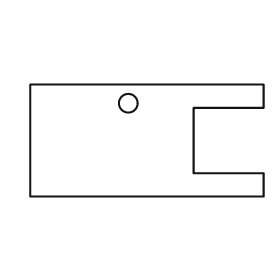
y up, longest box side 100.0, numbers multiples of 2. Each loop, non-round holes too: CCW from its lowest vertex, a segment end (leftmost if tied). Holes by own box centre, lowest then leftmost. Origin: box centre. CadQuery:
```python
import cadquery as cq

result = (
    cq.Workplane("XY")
    .moveTo(-50.0, -24.0)
    .lineTo(50.0, -24.0)
    .lineTo(50.0, -14.0)
    .lineTo(20.0, -14.0)
    .lineTo(20.0, 14.0)
    .lineTo(50.0, 14.0)
    .lineTo(50.0, 24.0)
    .lineTo(-50.0, 24.0)
    .close()
    .moveTo(-8.0, 16.0)
    .circle(4.0)
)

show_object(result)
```